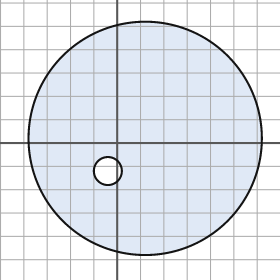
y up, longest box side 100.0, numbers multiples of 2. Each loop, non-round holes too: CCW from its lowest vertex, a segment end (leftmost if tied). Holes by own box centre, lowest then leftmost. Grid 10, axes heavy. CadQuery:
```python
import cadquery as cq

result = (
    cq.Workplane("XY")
    .moveTo(12.0, 2.0)
    .circle(50.0)
    .moveTo(-4.0, -12.0)
    .circle(6.0)
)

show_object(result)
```